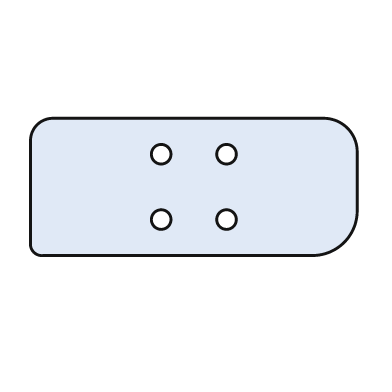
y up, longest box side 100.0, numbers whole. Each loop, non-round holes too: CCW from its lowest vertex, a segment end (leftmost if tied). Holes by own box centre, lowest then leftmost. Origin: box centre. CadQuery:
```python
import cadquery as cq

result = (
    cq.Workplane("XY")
    .moveTo(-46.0, -21.0)
    .lineTo(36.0, -21.0)
    .threePointArc((46.0, -17.0), (50.0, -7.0))
    .lineTo(50.0, 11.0)
    .threePointArc((47.0, 18.0), (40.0, 21.0))
    .lineTo(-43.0, 21.0)
    .threePointArc((-48.0, 19.0), (-50.0, 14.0))
    .lineTo(-50.0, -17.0)
    .threePointArc((-49.0, -20.0), (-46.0, -21.0))
    .close()
    .moveTo(-10.0, -10.0)
    .circle(3.0)
    .moveTo(10.0, -10.0)
    .circle(3.0)
    .moveTo(-10.0, 10.0)
    .circle(3.0)
    .moveTo(10.0, 10.0)
    .circle(3.0)
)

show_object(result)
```